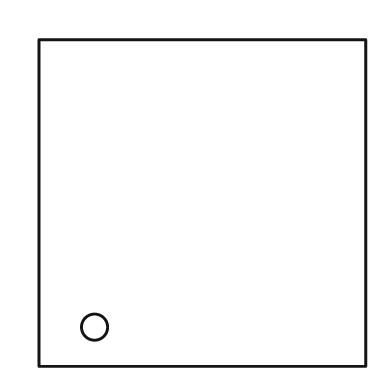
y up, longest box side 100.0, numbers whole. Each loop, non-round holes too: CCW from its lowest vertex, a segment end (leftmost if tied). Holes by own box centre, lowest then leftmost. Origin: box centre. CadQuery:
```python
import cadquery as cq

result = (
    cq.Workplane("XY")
    .moveTo(-50.0, -50.0)
    .lineTo(50.0, -50.0)
    .lineTo(50.0, 50.0)
    .lineTo(-50.0, 50.0)
    .close()
    .moveTo(-33.0, -38.0)
    .circle(4.0)
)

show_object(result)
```